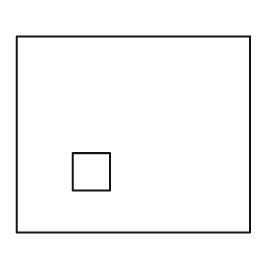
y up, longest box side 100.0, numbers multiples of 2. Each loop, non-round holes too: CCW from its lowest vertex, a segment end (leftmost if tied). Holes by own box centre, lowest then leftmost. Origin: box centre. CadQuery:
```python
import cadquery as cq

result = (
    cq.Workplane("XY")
    .moveTo(-50.0, -42.0)
    .lineTo(50.0, -42.0)
    .lineTo(50.0, 42.0)
    .lineTo(-50.0, 42.0)
    .close()
    .moveTo(-26.0, -24.0)
    .lineTo(-10.0, -24.0)
    .lineTo(-10.0, -8.0)
    .lineTo(-26.0, -8.0)
    .close()
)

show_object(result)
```